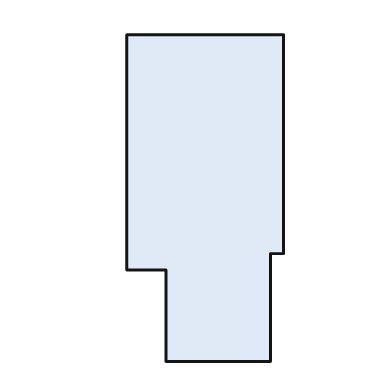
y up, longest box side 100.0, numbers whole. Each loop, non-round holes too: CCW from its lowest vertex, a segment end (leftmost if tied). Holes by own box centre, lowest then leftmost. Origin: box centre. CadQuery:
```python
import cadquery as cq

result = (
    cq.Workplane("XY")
    .moveTo(-12.0, -50.0)
    .lineTo(20.0, -50.0)
    .lineTo(20.0, -17.0)
    .lineTo(24.0, -17.0)
    .lineTo(24.0, 50.0)
    .lineTo(-24.0, 50.0)
    .lineTo(-24.0, -22.0)
    .lineTo(-12.0, -22.0)
    .close()
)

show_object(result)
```